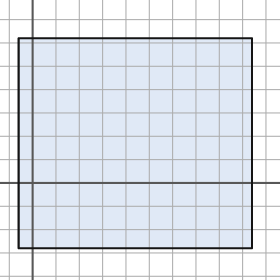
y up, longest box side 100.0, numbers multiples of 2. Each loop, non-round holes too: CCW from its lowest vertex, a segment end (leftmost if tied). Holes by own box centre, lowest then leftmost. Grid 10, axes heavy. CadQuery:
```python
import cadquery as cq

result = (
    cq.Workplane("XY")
    .moveTo(-6.0, -28.0)
    .lineTo(94.0, -28.0)
    .lineTo(94.0, 62.0)
    .lineTo(-6.0, 62.0)
    .close()
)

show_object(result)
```